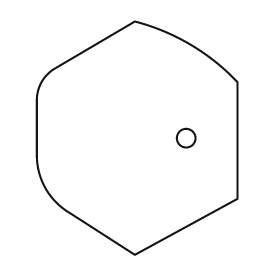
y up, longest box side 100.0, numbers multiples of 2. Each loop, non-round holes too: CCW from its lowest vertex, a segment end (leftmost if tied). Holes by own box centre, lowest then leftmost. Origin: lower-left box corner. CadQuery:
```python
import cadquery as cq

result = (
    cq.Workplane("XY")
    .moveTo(42.0, 0.0)
    .lineTo(86.0, 24.0)
    .lineTo(86.0, 74.0)
    .threePointArc((66.0, 90.0), (42.0, 100.0))
    .lineTo(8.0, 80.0)
    .threePointArc((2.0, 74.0), (0.0, 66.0))
    .lineTo(0.0, 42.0)
    .threePointArc((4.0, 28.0), (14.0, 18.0))
    .close()
    .moveTo(64.0, 50.0)
    .circle(4.0)
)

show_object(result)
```